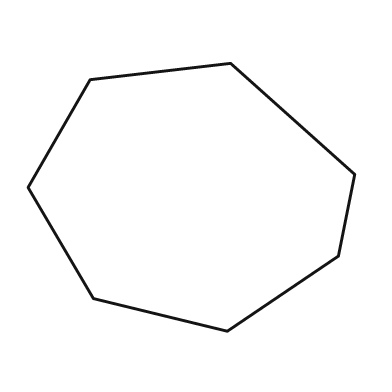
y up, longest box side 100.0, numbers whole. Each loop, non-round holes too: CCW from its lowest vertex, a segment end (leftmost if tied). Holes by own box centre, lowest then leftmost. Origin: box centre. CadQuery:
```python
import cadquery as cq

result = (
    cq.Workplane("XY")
    .moveTo(11.0, -41.0)
    .lineTo(45.0, -18.0)
    .lineTo(50.0, 7.0)
    .lineTo(12.0, 41.0)
    .lineTo(-31.0, 36.0)
    .lineTo(-50.0, 3.0)
    .lineTo(-30.0, -31.0)
    .close()
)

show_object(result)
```